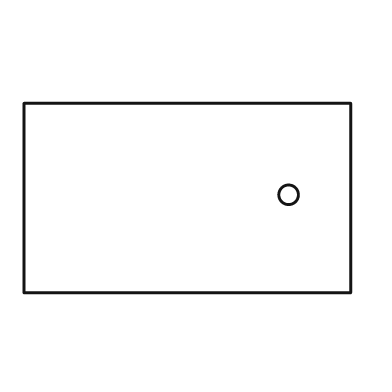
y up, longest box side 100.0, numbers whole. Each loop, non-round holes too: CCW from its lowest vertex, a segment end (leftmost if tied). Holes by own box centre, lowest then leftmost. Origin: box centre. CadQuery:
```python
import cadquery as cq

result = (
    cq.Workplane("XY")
    .moveTo(-50.0, -29.0)
    .lineTo(50.0, -29.0)
    .lineTo(50.0, 29.0)
    .lineTo(-50.0, 29.0)
    .close()
    .moveTo(31.0, 1.0)
    .circle(3.0)
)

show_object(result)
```